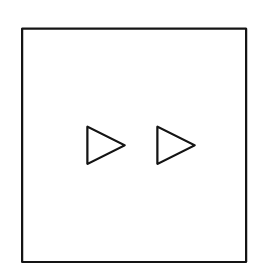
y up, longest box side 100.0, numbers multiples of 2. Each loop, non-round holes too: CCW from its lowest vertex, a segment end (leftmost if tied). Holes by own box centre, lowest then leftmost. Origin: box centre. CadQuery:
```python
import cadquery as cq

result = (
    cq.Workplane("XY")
    .moveTo(-48.0, -50.0)
    .lineTo(48.0, -50.0)
    .lineTo(48.0, 50.0)
    .lineTo(-48.0, 50.0)
    .close()
    .moveTo(-20.0, -8.0)
    .lineTo(-4.0, 0.0)
    .lineTo(-20.0, 8.0)
    .close()
    .moveTo(10.0, -8.0)
    .lineTo(26.0, 0.0)
    .lineTo(10.0, 8.0)
    .close()
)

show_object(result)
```